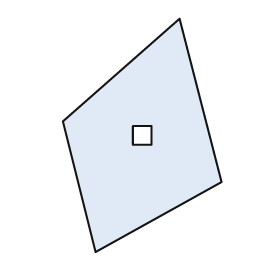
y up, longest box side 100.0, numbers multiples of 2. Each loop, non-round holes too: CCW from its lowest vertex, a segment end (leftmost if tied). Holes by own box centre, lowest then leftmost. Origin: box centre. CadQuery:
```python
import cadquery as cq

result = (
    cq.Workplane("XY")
    .moveTo(-20.0, -50.0)
    .lineTo(34.0, -20.0)
    .lineTo(16.0, 50.0)
    .lineTo(-34.0, 6.0)
    .close()
    .moveTo(-4.0, -4.0)
    .lineTo(4.0, -4.0)
    .lineTo(4.0, 4.0)
    .lineTo(-4.0, 4.0)
    .close()
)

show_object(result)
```